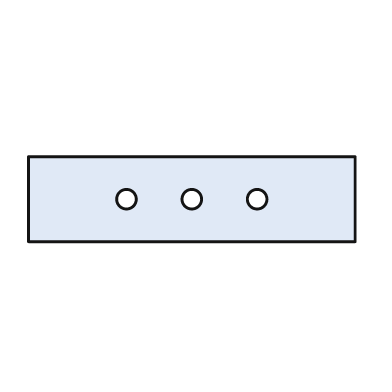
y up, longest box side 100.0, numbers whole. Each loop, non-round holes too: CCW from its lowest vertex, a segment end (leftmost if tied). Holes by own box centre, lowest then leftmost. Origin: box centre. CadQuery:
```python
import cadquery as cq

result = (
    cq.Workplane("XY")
    .moveTo(-50.0, -13.0)
    .lineTo(50.0, -13.0)
    .lineTo(50.0, 13.0)
    .lineTo(-50.0, 13.0)
    .close()
    .moveTo(-20.0, 0.0)
    .circle(3.0)
    .moveTo(0.0, 0.0)
    .circle(3.0)
    .moveTo(20.0, 0.0)
    .circle(3.0)
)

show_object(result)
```